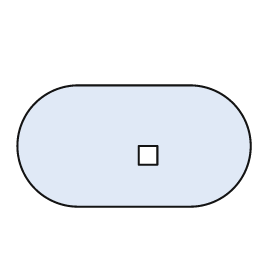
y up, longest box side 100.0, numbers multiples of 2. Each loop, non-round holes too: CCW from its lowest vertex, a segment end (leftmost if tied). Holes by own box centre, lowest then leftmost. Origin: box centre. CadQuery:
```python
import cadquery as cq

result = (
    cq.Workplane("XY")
    .moveTo(-24.0, -26.0)
    .lineTo(24.0, -26.0)
    .threePointArc((50.0, 0.0), (24.0, 26.0))
    .lineTo(-24.0, 26.0)
    .threePointArc((-50.0, 0.0), (-24.0, -26.0))
    .close()
    .moveTo(2.0, -8.0)
    .lineTo(10.0, -8.0)
    .lineTo(10.0, 0.0)
    .lineTo(2.0, 0.0)
    .close()
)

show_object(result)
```